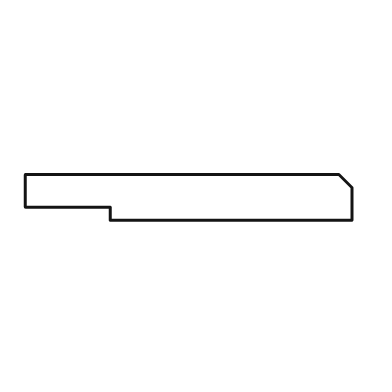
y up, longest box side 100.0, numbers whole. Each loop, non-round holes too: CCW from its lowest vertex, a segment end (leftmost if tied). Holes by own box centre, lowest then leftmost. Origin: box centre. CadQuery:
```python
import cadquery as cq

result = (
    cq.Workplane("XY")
    .moveTo(-24.0, -7.0)
    .lineTo(50.0, -7.0)
    .lineTo(50.0, 3.0)
    .lineTo(46.0, 7.0)
    .lineTo(-50.0, 7.0)
    .lineTo(-50.0, -3.0)
    .lineTo(-24.0, -3.0)
    .close()
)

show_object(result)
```